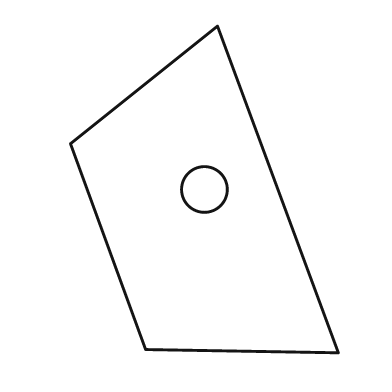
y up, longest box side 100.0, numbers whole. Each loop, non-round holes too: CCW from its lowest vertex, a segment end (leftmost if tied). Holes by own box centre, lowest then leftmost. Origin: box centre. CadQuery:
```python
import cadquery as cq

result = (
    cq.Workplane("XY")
    .moveTo(41.0, -50.0)
    .lineTo(4.0, 50.0)
    .lineTo(-41.0, 14.0)
    .lineTo(-18.0, -49.0)
    .close()
    .moveTo(0.0, 0.0)
    .circle(7.0)
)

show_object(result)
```